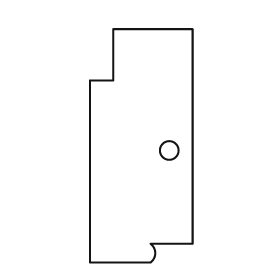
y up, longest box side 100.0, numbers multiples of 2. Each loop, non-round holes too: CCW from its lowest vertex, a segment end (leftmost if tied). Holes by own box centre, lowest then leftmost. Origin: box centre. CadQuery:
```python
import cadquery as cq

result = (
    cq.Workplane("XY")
    .moveTo(-22.0, -50.0)
    .lineTo(4.0, -50.0)
    .threePointArc((6.0, -46.0), (4.0, -42.0))
    .lineTo(22.0, -42.0)
    .lineTo(22.0, 50.0)
    .lineTo(-12.0, 50.0)
    .lineTo(-12.0, 28.0)
    .lineTo(-22.0, 28.0)
    .close()
    .moveTo(12.0, -2.0)
    .circle(4.0)
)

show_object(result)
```